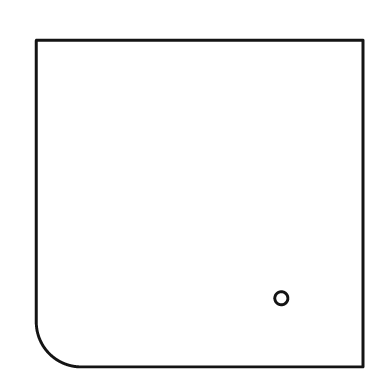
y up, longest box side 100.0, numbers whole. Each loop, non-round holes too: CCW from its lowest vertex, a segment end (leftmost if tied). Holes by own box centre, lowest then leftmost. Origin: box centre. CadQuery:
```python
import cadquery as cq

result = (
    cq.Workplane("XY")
    .moveTo(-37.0, -50.0)
    .lineTo(50.0, -50.0)
    .lineTo(50.0, 50.0)
    .lineTo(-50.0, 50.0)
    .lineTo(-50.0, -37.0)
    .threePointArc((-46.0, -46.0), (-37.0, -50.0))
    .close()
    .moveTo(25.0, -29.0)
    .circle(2.0)
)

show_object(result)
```